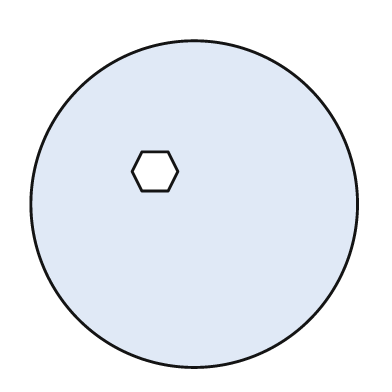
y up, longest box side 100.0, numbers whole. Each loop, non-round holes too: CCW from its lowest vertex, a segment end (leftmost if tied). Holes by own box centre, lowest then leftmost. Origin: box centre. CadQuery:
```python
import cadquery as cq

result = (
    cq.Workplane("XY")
    .moveTo(0.0, 0.0)
    .circle(50.0)
    .moveTo(-16.0, 4.0)
    .lineTo(-8.0, 4.0)
    .lineTo(-5.0, 10.0)
    .lineTo(-8.0, 16.0)
    .lineTo(-16.0, 16.0)
    .lineTo(-19.0, 10.0)
    .close()
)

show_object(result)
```